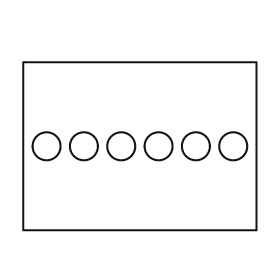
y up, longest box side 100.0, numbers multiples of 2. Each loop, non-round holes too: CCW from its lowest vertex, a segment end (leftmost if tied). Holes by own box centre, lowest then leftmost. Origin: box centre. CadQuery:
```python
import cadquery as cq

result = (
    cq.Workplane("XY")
    .moveTo(-50.0, -36.0)
    .lineTo(50.0, -36.0)
    .lineTo(50.0, 36.0)
    .lineTo(-50.0, 36.0)
    .close()
    .moveTo(-40.0, 0.0)
    .circle(6.0)
    .moveTo(-24.0, 0.0)
    .circle(6.0)
    .moveTo(-8.0, 0.0)
    .circle(6.0)
    .moveTo(8.0, 0.0)
    .circle(6.0)
    .moveTo(24.0, 0.0)
    .circle(6.0)
    .moveTo(40.0, 0.0)
    .circle(6.0)
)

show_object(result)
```